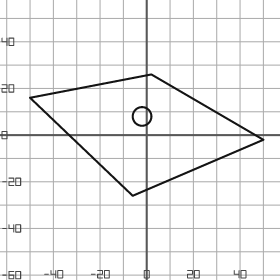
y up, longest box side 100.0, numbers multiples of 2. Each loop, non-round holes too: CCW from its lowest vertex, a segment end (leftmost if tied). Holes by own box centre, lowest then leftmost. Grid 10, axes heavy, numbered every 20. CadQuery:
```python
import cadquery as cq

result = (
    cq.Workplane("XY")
    .moveTo(-6.0, -26.0)
    .lineTo(50.0, -2.0)
    .lineTo(2.0, 26.0)
    .lineTo(-50.0, 16.0)
    .close()
    .moveTo(-2.0, 8.0)
    .circle(4.0)
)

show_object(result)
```